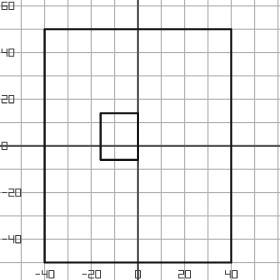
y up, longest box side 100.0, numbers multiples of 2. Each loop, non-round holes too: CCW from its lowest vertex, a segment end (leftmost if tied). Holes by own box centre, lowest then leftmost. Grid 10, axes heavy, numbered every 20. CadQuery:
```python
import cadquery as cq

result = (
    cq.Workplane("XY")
    .moveTo(-40.0, -50.0)
    .lineTo(40.0, -50.0)
    .lineTo(40.0, 50.0)
    .lineTo(-40.0, 50.0)
    .close()
    .moveTo(-16.0, -6.0)
    .lineTo(0.0, -6.0)
    .lineTo(0.0, 14.0)
    .lineTo(-16.0, 14.0)
    .close()
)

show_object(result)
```